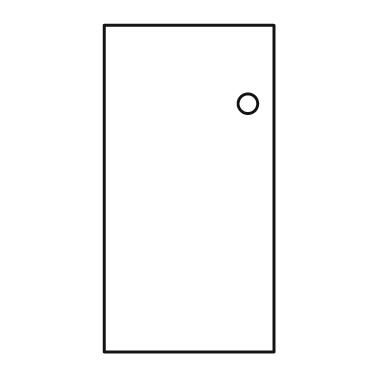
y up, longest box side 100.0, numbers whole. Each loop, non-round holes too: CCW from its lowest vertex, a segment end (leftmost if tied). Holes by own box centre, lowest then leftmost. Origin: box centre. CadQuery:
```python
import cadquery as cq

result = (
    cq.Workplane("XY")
    .moveTo(-26.0, -50.0)
    .lineTo(26.0, -50.0)
    .lineTo(26.0, 50.0)
    .lineTo(-26.0, 50.0)
    .close()
    .moveTo(18.0, 26.0)
    .circle(3.0)
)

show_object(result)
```